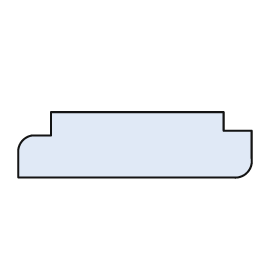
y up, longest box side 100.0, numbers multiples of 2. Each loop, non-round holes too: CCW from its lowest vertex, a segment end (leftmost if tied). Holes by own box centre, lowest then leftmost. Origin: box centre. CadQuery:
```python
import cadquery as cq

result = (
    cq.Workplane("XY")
    .moveTo(-50.0, -14.0)
    .lineTo(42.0, -14.0)
    .threePointArc((48.0, -12.0), (50.0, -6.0))
    .lineTo(50.0, 6.0)
    .lineTo(38.0, 6.0)
    .lineTo(38.0, 14.0)
    .lineTo(-36.0, 14.0)
    .lineTo(-36.0, 4.0)
    .lineTo(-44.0, 4.0)
    .threePointArc((-48.0, 2.0), (-50.0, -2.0))
    .close()
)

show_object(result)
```